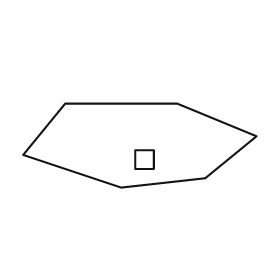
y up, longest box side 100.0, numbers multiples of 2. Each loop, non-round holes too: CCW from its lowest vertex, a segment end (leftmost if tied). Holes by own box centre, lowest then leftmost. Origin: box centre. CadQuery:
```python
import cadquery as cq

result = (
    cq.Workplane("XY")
    .moveTo(-8.0, -18.0)
    .lineTo(28.0, -14.0)
    .lineTo(50.0, 4.0)
    .lineTo(16.0, 18.0)
    .lineTo(-32.0, 18.0)
    .lineTo(-50.0, -4.0)
    .close()
    .moveTo(-2.0, -10.0)
    .lineTo(6.0, -10.0)
    .lineTo(6.0, -2.0)
    .lineTo(-2.0, -2.0)
    .close()
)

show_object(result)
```